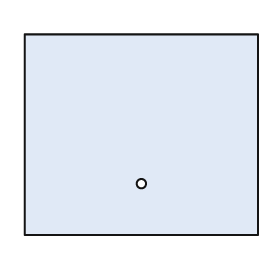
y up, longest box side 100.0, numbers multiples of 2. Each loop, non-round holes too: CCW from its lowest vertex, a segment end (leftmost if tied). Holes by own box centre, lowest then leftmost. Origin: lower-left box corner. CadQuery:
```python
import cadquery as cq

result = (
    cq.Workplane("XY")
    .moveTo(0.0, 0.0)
    .lineTo(100.0, 0.0)
    .lineTo(100.0, 86.0)
    .lineTo(0.0, 86.0)
    .close()
    .moveTo(50.0, 22.0)
    .circle(2.0)
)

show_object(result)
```